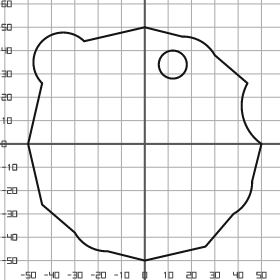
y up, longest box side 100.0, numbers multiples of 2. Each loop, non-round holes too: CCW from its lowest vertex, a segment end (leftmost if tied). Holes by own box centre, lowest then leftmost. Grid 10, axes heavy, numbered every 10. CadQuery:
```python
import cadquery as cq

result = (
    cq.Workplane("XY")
    .moveTo(0.0, -50.0)
    .lineTo(26.0, -44.0)
    .lineTo(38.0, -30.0)
    .threePointArc((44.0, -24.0), (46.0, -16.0))
    .lineTo(50.0, 0.0)
    .threePointArc((42.0, 12.0), (44.0, 26.0))
    .lineTo(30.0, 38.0)
    .threePointArc((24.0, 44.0), (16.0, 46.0))
    .lineTo(0.0, 50.0)
    .lineTo(-26.0, 44.0)
    .threePointArc((-44.0, 44.0), (-44.0, 26.0))
    .lineTo(-50.0, 0.0)
    .lineTo(-44.0, -26.0)
    .lineTo(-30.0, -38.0)
    .threePointArc((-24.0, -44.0), (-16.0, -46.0))
    .close()
    .moveTo(12.0, 34.0)
    .circle(6.0)
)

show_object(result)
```